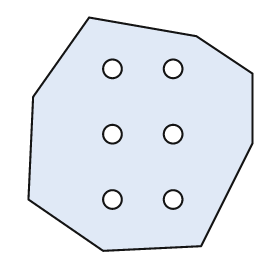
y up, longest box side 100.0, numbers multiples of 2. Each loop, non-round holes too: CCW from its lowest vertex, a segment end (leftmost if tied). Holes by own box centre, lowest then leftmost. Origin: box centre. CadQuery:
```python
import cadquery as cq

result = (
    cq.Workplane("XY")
    .moveTo(-16.0, -50.0)
    .lineTo(26.0, -48.0)
    .lineTo(48.0, -4.0)
    .lineTo(48.0, 26.0)
    .lineTo(24.0, 42.0)
    .lineTo(-22.0, 50.0)
    .lineTo(-46.0, 16.0)
    .lineTo(-48.0, -28.0)
    .close()
    .moveTo(-12.0, -28.0)
    .circle(4.0)
    .moveTo(14.0, -28.0)
    .circle(4.0)
    .moveTo(-12.0, 0.0)
    .circle(4.0)
    .moveTo(14.0, 0.0)
    .circle(4.0)
    .moveTo(-12.0, 28.0)
    .circle(4.0)
    .moveTo(14.0, 28.0)
    .circle(4.0)
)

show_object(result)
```